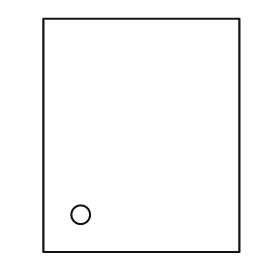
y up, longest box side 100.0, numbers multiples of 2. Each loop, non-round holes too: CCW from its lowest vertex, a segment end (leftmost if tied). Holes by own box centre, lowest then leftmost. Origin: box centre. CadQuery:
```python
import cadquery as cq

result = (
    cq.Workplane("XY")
    .moveTo(-42.0, -50.0)
    .lineTo(42.0, -50.0)
    .lineTo(42.0, 50.0)
    .lineTo(-42.0, 50.0)
    .close()
    .moveTo(-26.0, -34.0)
    .circle(4.0)
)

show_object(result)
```